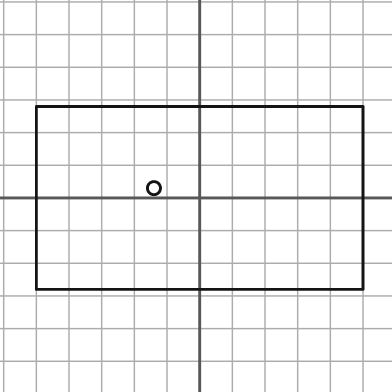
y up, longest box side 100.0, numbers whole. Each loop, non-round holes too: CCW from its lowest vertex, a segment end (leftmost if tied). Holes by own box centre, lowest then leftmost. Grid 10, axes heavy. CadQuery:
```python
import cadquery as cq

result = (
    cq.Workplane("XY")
    .moveTo(-50.0, -28.0)
    .lineTo(50.0, -28.0)
    .lineTo(50.0, 28.0)
    .lineTo(-50.0, 28.0)
    .close()
    .moveTo(-14.0, 3.0)
    .circle(2.0)
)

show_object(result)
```